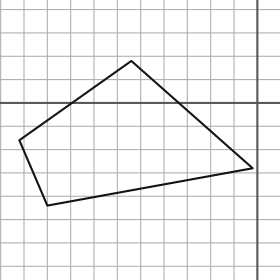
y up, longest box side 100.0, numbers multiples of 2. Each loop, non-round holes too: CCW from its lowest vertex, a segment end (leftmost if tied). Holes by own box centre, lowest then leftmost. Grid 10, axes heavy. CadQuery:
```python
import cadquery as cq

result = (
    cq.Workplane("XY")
    .moveTo(-90.0, -44.0)
    .lineTo(-2.0, -28.0)
    .lineTo(-54.0, 18.0)
    .lineTo(-102.0, -16.0)
    .close()
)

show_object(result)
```